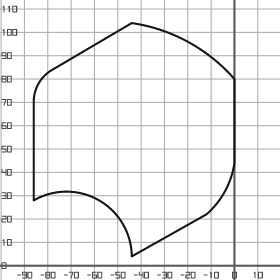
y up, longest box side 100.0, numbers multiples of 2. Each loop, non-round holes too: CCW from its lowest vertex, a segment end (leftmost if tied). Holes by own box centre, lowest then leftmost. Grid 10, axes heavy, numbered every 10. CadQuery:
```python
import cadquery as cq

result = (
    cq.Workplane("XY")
    .moveTo(-44.0, 4.0)
    .lineTo(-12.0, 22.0)
    .threePointArc((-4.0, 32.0), (0.0, 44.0))
    .lineTo(0.0, 80.0)
    .threePointArc((-20.0, 96.0), (-44.0, 104.0))
    .lineTo(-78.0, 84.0)
    .threePointArc((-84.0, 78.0), (-86.0, 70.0))
    .lineTo(-86.0, 28.0)
    .threePointArc((-58.0, 28.0), (-44.0, 4.0))
    .close()
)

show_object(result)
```